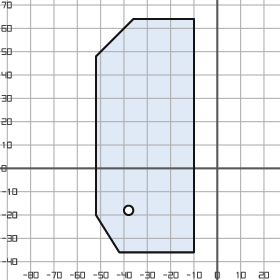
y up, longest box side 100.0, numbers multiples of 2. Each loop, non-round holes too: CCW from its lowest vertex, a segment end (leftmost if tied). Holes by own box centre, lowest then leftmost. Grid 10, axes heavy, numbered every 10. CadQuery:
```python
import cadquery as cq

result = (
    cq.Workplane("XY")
    .moveTo(-42.0, -36.0)
    .lineTo(-10.0, -36.0)
    .lineTo(-10.0, 64.0)
    .lineTo(-36.0, 64.0)
    .lineTo(-52.0, 48.0)
    .lineTo(-52.0, -20.0)
    .close()
    .moveTo(-38.0, -18.0)
    .circle(2.0)
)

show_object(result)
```